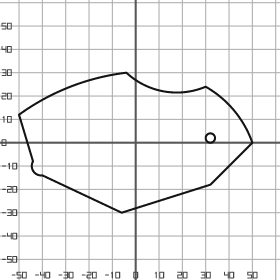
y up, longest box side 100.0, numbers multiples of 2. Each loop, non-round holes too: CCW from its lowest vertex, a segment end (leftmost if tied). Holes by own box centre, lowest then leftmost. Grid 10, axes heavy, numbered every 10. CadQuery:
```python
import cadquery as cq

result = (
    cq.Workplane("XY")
    .moveTo(-6.0, -30.0)
    .lineTo(32.0, -18.0)
    .lineTo(50.0, 0.0)
    .threePointArc((42.0, 14.0), (30.0, 24.0))
    .threePointArc((12.0, 22.0), (-4.0, 30.0))
    .threePointArc((-28.0, 24.0), (-50.0, 12.0))
    .lineTo(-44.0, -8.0)
    .threePointArc((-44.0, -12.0), (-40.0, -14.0))
    .close()
    .moveTo(32.0, 2.0)
    .circle(2.0)
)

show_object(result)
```